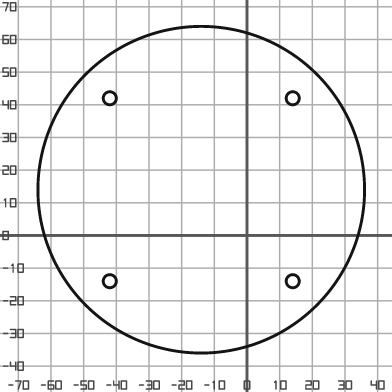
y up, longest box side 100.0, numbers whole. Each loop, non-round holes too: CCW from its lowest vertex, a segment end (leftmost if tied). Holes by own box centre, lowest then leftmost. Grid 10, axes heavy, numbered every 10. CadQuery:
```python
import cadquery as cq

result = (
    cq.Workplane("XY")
    .moveTo(-14.0, 14.0)
    .circle(50.0)
    .moveTo(-42.0, -14.0)
    .circle(2.0)
    .moveTo(14.0, -14.0)
    .circle(2.0)
    .moveTo(-42.0, 42.0)
    .circle(2.0)
    .moveTo(14.0, 42.0)
    .circle(2.0)
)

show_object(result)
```